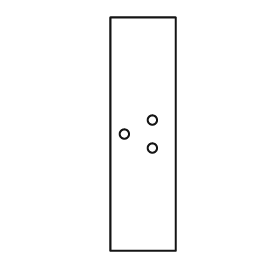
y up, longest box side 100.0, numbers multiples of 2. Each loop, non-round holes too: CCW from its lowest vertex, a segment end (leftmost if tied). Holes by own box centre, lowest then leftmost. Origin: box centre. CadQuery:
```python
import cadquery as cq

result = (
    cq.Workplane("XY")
    .moveTo(-14.0, -50.0)
    .lineTo(14.0, -50.0)
    .lineTo(14.0, 50.0)
    .lineTo(-14.0, 50.0)
    .close()
    .moveTo(4.0, -6.0)
    .circle(2.0)
    .moveTo(-8.0, 0.0)
    .circle(2.0)
    .moveTo(4.0, 6.0)
    .circle(2.0)
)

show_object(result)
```